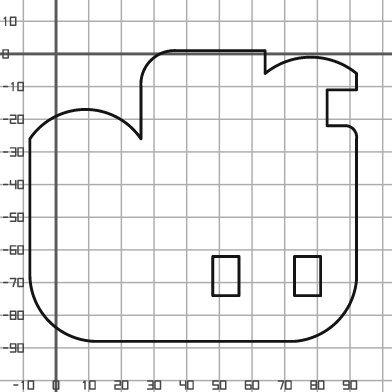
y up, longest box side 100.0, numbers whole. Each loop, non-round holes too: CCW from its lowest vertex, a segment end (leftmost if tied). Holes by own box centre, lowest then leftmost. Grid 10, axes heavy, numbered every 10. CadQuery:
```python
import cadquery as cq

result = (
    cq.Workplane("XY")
    .moveTo(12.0, -88.0)
    .lineTo(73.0, -88.0)
    .threePointArc((86.0, -82.0), (92.0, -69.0))
    .lineTo(92.0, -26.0)
    .threePointArc((91.0, -23.0), (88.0, -22.0))
    .lineTo(83.0, -22.0)
    .lineTo(83.0, -11.0)
    .lineTo(92.0, -11.0)
    .lineTo(92.0, -6.0)
    .threePointArc((78.0, -1.0), (64.0, -6.0))
    .lineTo(64.0, 1.0)
    .lineTo(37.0, 1.0)
    .threePointArc((29.0, -2.0), (26.0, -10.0))
    .lineTo(26.0, -26.0)
    .threePointArc((9.0, -17.0), (-8.0, -26.0))
    .lineTo(-8.0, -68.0)
    .threePointArc((-2.0, -82.0), (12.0, -88.0))
    .close()
    .moveTo(48.0, -74.0)
    .lineTo(56.0, -74.0)
    .lineTo(56.0, -62.0)
    .lineTo(48.0, -62.0)
    .close()
    .moveTo(73.0, -74.0)
    .lineTo(81.0, -74.0)
    .lineTo(81.0, -62.0)
    .lineTo(73.0, -62.0)
    .close()
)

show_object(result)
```